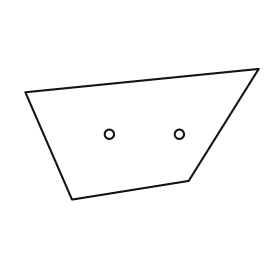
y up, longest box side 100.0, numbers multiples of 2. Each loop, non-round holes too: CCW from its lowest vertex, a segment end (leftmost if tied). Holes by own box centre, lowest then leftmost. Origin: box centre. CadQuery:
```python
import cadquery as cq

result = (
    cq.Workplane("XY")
    .moveTo(-30.0, -28.0)
    .lineTo(20.0, -20.0)
    .lineTo(50.0, 28.0)
    .lineTo(-50.0, 18.0)
    .close()
    .moveTo(-14.0, 0.0)
    .circle(2.0)
    .moveTo(16.0, 0.0)
    .circle(2.0)
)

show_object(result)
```